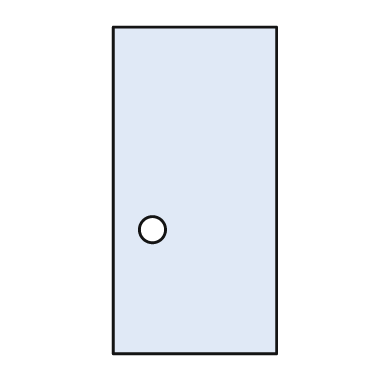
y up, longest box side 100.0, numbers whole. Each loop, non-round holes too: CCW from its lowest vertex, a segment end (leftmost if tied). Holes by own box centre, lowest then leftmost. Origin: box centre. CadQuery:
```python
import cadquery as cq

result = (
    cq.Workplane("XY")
    .moveTo(-25.0, -50.0)
    .lineTo(25.0, -50.0)
    .lineTo(25.0, 50.0)
    .lineTo(-25.0, 50.0)
    .close()
    .moveTo(-13.0, -12.0)
    .circle(4.0)
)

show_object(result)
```